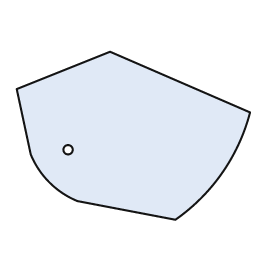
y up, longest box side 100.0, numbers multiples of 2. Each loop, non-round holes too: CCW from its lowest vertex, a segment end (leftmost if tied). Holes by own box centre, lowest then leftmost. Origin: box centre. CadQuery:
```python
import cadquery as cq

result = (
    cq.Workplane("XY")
    .moveTo(18.0, -36.0)
    .threePointArc((38.0, -16.0), (50.0, 10.0))
    .lineTo(-10.0, 36.0)
    .lineTo(-50.0, 20.0)
    .lineTo(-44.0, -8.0)
    .threePointArc((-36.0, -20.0), (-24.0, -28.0))
    .close()
    .moveTo(-28.0, -6.0)
    .circle(2.0)
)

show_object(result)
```